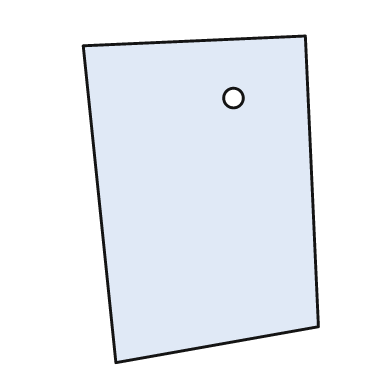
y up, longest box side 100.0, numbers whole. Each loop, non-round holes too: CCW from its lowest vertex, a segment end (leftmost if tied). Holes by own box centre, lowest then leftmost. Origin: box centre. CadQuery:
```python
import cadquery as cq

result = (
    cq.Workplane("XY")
    .moveTo(-26.0, -50.0)
    .lineTo(36.0, -39.0)
    .lineTo(32.0, 50.0)
    .lineTo(-36.0, 47.0)
    .close()
    .moveTo(10.0, 31.0)
    .circle(3.0)
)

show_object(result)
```